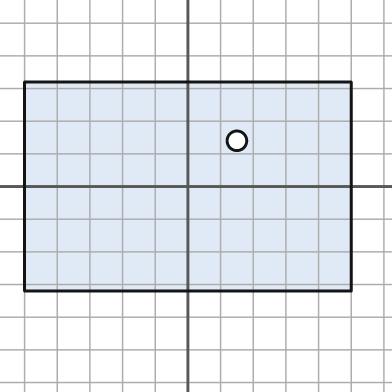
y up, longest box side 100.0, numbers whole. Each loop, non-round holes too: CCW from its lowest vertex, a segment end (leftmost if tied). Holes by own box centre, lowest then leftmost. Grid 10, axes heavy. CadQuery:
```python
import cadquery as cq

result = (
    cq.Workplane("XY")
    .moveTo(-50.0, -32.0)
    .lineTo(50.0, -32.0)
    .lineTo(50.0, 32.0)
    .lineTo(-50.0, 32.0)
    .close()
    .moveTo(15.0, 14.0)
    .circle(3.0)
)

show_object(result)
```